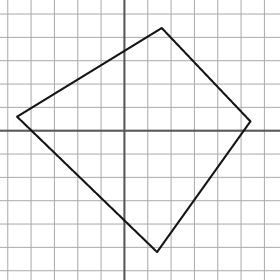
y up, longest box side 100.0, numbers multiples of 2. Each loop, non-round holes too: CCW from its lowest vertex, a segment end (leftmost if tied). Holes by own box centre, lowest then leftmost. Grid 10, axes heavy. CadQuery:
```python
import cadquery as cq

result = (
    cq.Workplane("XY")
    .moveTo(14.0, -52.0)
    .lineTo(54.0, 4.0)
    .lineTo(16.0, 44.0)
    .lineTo(-46.0, 6.0)
    .close()
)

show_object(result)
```